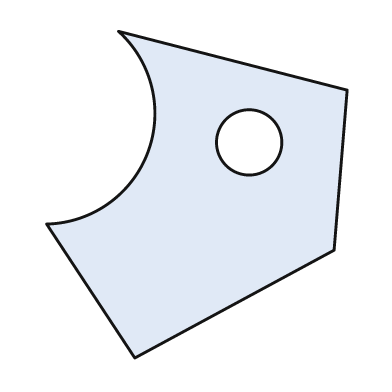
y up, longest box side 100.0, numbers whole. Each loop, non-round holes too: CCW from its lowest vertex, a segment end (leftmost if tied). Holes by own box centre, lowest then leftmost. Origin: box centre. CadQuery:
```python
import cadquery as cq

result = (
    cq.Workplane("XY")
    .moveTo(-19.0, -50.0)
    .lineTo(42.0, -17.0)
    .lineTo(46.0, 32.0)
    .lineTo(-24.0, 50.0)
    .threePointArc((-15.0, 13.0), (-46.0, -9.0))
    .close()
    .moveTo(16.0, 16.0)
    .circle(10.0)
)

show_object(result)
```